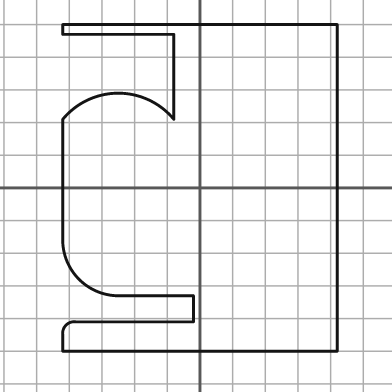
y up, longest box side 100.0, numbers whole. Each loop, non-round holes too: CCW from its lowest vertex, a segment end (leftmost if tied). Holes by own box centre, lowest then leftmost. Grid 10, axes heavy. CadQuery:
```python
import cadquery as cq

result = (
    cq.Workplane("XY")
    .moveTo(-42.0, -50.0)
    .lineTo(42.0, -50.0)
    .lineTo(42.0, 50.0)
    .lineTo(-42.0, 50.0)
    .lineTo(-42.0, 47.0)
    .lineTo(-8.0, 47.0)
    .lineTo(-8.0, 21.0)
    .threePointArc((-25.0, 29.0), (-42.0, 21.0))
    .lineTo(-42.0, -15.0)
    .threePointArc((-37.0, -28.0), (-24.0, -33.0))
    .lineTo(-2.0, -33.0)
    .lineTo(-2.0, -41.0)
    .lineTo(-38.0, -41.0)
    .threePointArc((-41.0, -42.0), (-42.0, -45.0))
    .close()
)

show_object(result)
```